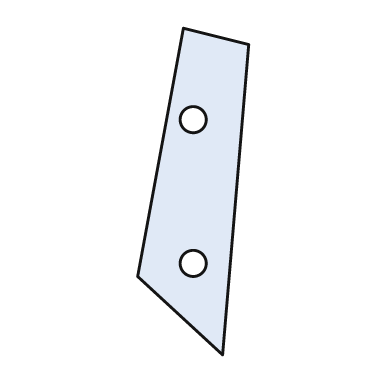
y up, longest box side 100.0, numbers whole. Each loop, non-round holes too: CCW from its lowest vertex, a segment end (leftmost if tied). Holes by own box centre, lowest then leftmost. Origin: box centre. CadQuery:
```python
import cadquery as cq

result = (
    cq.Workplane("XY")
    .moveTo(9.0, -50.0)
    .lineTo(17.0, 45.0)
    .lineTo(-3.0, 50.0)
    .lineTo(-17.0, -26.0)
    .close()
    .moveTo(0.0, -22.0)
    .circle(4.0)
    .moveTo(0.0, 22.0)
    .circle(4.0)
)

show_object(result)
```